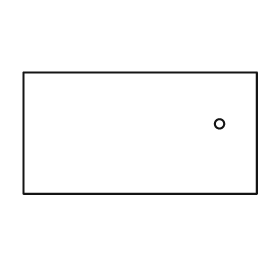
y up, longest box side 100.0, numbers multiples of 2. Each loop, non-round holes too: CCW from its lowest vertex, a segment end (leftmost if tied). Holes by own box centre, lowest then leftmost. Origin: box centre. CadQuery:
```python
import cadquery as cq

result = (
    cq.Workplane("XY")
    .moveTo(-50.0, -26.0)
    .lineTo(50.0, -26.0)
    .lineTo(50.0, 26.0)
    .lineTo(-50.0, 26.0)
    .close()
    .moveTo(34.0, 4.0)
    .circle(2.0)
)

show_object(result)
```